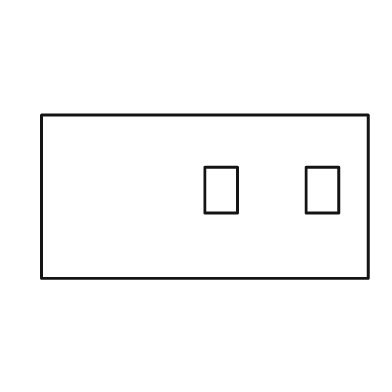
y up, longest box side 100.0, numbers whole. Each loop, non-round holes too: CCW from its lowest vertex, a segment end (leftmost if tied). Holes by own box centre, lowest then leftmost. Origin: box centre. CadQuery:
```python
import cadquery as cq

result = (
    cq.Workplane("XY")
    .moveTo(-50.0, -25.0)
    .lineTo(50.0, -25.0)
    .lineTo(50.0, 25.0)
    .lineTo(-50.0, 25.0)
    .close()
    .moveTo(0.0, -5.0)
    .lineTo(10.0, -5.0)
    .lineTo(10.0, 9.0)
    .lineTo(0.0, 9.0)
    .close()
    .moveTo(31.0, -5.0)
    .lineTo(41.0, -5.0)
    .lineTo(41.0, 9.0)
    .lineTo(31.0, 9.0)
    .close()
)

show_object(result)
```